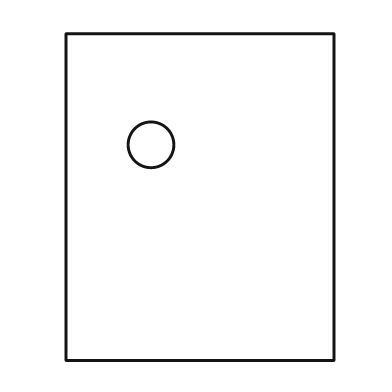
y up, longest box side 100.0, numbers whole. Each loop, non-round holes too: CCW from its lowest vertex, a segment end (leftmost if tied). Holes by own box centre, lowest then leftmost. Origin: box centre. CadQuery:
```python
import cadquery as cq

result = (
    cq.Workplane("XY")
    .moveTo(-41.0, -50.0)
    .lineTo(41.0, -50.0)
    .lineTo(41.0, 50.0)
    .lineTo(-41.0, 50.0)
    .close()
    .moveTo(-15.0, 16.0)
    .circle(7.0)
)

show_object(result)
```